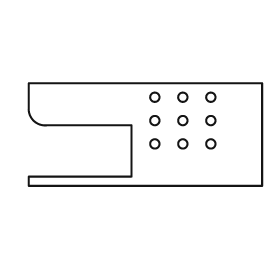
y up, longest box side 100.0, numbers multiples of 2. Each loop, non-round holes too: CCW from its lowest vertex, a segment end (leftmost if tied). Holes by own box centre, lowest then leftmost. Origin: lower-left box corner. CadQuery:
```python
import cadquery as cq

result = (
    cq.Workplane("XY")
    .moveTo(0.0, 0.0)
    .lineTo(100.0, 0.0)
    .lineTo(100.0, 44.0)
    .lineTo(0.0, 44.0)
    .lineTo(0.0, 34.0)
    .threePointArc((2.0, 28.0), (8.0, 26.0))
    .lineTo(44.0, 26.0)
    .lineTo(44.0, 4.0)
    .lineTo(0.0, 4.0)
    .close()
    .moveTo(54.0, 18.0)
    .circle(2.0)
    .moveTo(66.0, 18.0)
    .circle(2.0)
    .moveTo(78.0, 18.0)
    .circle(2.0)
    .moveTo(54.0, 28.0)
    .circle(2.0)
    .moveTo(66.0, 28.0)
    .circle(2.0)
    .moveTo(78.0, 28.0)
    .circle(2.0)
    .moveTo(54.0, 38.0)
    .circle(2.0)
    .moveTo(66.0, 38.0)
    .circle(2.0)
    .moveTo(78.0, 38.0)
    .circle(2.0)
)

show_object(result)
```